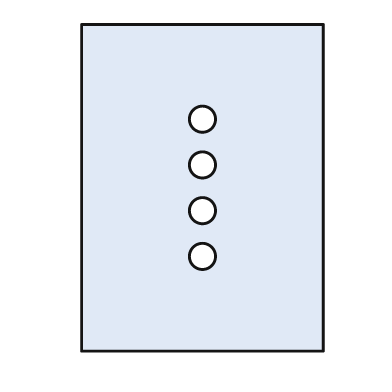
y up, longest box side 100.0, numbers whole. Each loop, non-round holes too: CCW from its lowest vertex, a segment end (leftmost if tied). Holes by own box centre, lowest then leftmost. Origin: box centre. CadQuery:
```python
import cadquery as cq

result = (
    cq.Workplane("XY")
    .moveTo(-37.0, -50.0)
    .lineTo(37.0, -50.0)
    .lineTo(37.0, 50.0)
    .lineTo(-37.0, 50.0)
    .close()
    .moveTo(0.0, -21.0)
    .circle(4.0)
    .moveTo(0.0, -7.0)
    .circle(4.0)
    .moveTo(0.0, 7.0)
    .circle(4.0)
    .moveTo(0.0, 21.0)
    .circle(4.0)
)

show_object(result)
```